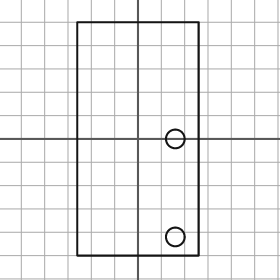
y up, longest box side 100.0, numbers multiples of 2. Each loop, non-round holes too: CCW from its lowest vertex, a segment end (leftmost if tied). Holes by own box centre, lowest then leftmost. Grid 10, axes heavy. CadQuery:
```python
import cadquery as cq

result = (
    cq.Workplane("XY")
    .moveTo(-26.0, -50.0)
    .lineTo(26.0, -50.0)
    .lineTo(26.0, 50.0)
    .lineTo(-26.0, 50.0)
    .close()
    .moveTo(16.0, -42.0)
    .circle(4.0)
    .moveTo(16.0, 0.0)
    .circle(4.0)
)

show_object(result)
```